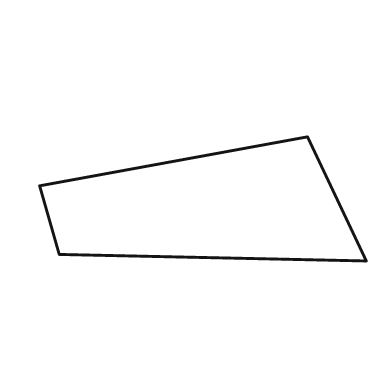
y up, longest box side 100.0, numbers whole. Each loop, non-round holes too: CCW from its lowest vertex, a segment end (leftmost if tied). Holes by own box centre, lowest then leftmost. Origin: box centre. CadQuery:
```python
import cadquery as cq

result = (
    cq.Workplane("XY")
    .moveTo(50.0, -19.0)
    .lineTo(32.0, 19.0)
    .lineTo(-50.0, 4.0)
    .lineTo(-44.0, -17.0)
    .close()
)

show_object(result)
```